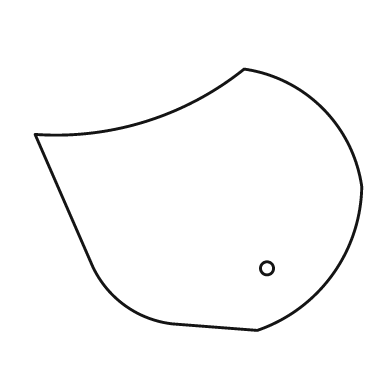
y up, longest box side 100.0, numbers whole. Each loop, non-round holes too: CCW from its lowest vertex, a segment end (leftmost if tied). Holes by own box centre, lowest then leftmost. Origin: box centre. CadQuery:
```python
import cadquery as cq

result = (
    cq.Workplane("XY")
    .moveTo(18.0, -40.0)
    .threePointArc((41.0, -23.0), (50.0, 4.0))
    .threePointArc((38.0, 28.0), (14.0, 40.0))
    .threePointArc((-16.0, 24.0), (-50.0, 20.0))
    .lineTo(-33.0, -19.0)
    .threePointArc((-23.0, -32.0), (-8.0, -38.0))
    .close()
    .moveTo(21.0, -21.0)
    .circle(2.0)
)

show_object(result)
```